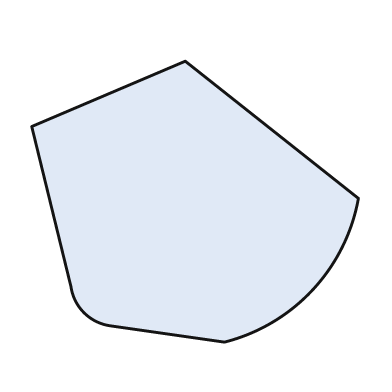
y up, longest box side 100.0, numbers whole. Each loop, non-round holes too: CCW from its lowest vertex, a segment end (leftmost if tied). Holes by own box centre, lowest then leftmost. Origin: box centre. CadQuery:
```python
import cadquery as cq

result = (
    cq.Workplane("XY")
    .moveTo(9.0, -43.0)
    .threePointArc((36.0, -27.0), (50.0, 1.0))
    .lineTo(-3.0, 43.0)
    .lineTo(-50.0, 23.0)
    .lineTo(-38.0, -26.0)
    .threePointArc((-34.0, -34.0), (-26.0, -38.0))
    .close()
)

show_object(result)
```